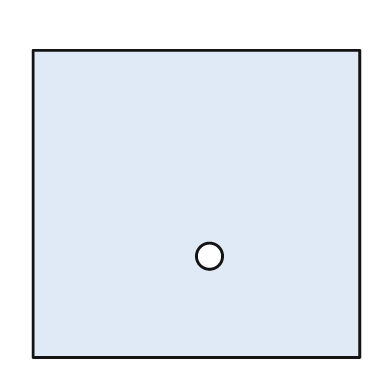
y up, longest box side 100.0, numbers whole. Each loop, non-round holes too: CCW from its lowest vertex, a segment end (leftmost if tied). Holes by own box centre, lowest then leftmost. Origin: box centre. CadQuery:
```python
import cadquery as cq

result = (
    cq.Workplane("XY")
    .moveTo(-50.0, -47.0)
    .lineTo(50.0, -47.0)
    .lineTo(50.0, 47.0)
    .lineTo(-50.0, 47.0)
    .close()
    .moveTo(4.0, -16.0)
    .circle(4.0)
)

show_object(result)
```